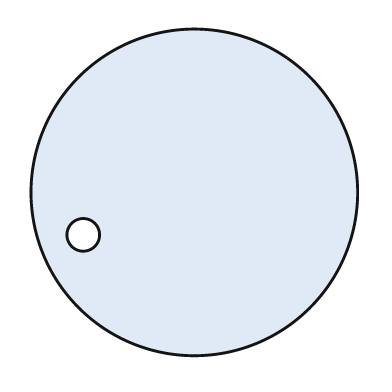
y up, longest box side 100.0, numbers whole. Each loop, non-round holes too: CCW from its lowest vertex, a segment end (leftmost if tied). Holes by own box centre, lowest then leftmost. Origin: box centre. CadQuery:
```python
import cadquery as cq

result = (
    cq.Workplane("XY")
    .moveTo(0.0, 0.0)
    .circle(50.0)
    .moveTo(-34.0, -13.0)
    .circle(5.0)
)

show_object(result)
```